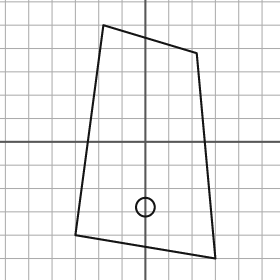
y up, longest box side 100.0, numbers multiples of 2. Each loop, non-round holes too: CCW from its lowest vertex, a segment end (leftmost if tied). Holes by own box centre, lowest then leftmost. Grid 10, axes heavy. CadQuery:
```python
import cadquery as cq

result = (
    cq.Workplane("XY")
    .moveTo(30.0, -50.0)
    .lineTo(22.0, 38.0)
    .lineTo(-18.0, 50.0)
    .lineTo(-30.0, -40.0)
    .close()
    .moveTo(0.0, -28.0)
    .circle(4.0)
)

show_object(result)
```